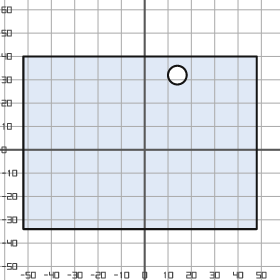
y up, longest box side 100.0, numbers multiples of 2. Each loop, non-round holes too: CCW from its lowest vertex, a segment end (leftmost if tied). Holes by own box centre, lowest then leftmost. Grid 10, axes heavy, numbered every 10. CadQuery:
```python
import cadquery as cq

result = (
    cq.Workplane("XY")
    .moveTo(-52.0, -34.0)
    .lineTo(48.0, -34.0)
    .lineTo(48.0, 40.0)
    .lineTo(-52.0, 40.0)
    .close()
    .moveTo(14.0, 32.0)
    .circle(4.0)
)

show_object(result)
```